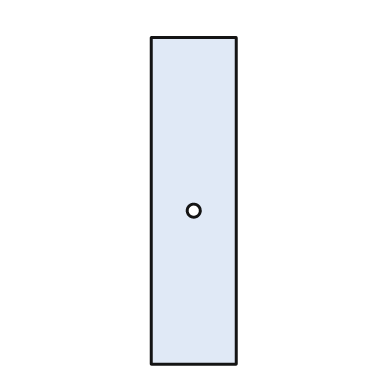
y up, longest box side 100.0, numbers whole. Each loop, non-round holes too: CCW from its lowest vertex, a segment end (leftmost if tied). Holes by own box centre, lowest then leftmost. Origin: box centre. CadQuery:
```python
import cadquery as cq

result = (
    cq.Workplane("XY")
    .moveTo(-13.0, -50.0)
    .lineTo(13.0, -50.0)
    .lineTo(13.0, 50.0)
    .lineTo(-13.0, 50.0)
    .close()
    .moveTo(0.0, -3.0)
    .circle(2.0)
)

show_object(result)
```